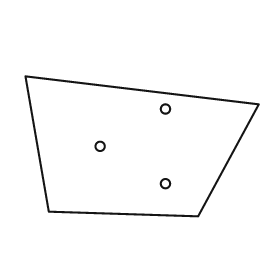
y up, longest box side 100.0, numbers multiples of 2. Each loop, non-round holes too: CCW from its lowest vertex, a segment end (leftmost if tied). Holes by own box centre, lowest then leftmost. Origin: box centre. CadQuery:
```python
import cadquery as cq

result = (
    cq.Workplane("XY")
    .moveTo(24.0, -30.0)
    .lineTo(50.0, 18.0)
    .lineTo(-50.0, 30.0)
    .lineTo(-40.0, -28.0)
    .close()
    .moveTo(10.0, -16.0)
    .circle(2.0)
    .moveTo(-18.0, 0.0)
    .circle(2.0)
    .moveTo(10.0, 16.0)
    .circle(2.0)
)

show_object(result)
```